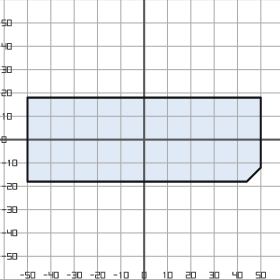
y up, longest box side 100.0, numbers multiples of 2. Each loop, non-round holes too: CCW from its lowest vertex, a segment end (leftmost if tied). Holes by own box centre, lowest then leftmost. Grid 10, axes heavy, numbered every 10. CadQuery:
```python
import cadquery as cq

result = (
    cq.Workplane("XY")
    .moveTo(-50.0, -18.0)
    .lineTo(44.0, -18.0)
    .lineTo(50.0, -12.0)
    .lineTo(50.0, 18.0)
    .lineTo(-50.0, 18.0)
    .close()
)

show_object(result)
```